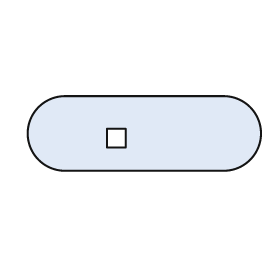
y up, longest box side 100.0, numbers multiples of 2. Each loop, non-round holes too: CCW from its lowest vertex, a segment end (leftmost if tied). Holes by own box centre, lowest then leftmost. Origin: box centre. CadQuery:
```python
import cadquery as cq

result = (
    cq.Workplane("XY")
    .moveTo(-34.0, -16.0)
    .lineTo(34.0, -16.0)
    .threePointArc((50.0, 0.0), (34.0, 16.0))
    .lineTo(-34.0, 16.0)
    .threePointArc((-50.0, 0.0), (-34.0, -16.0))
    .close()
    .moveTo(-16.0, -6.0)
    .lineTo(-8.0, -6.0)
    .lineTo(-8.0, 2.0)
    .lineTo(-16.0, 2.0)
    .close()
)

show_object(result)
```